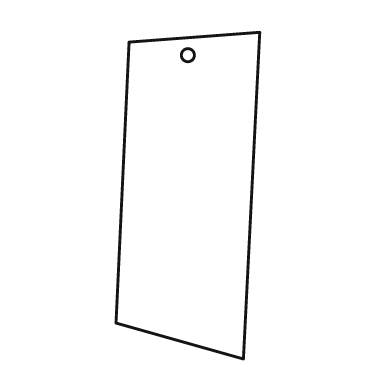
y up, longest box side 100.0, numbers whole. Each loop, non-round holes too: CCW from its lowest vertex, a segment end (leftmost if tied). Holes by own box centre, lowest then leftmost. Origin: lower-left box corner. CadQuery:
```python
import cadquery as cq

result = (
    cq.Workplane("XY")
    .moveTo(39.0, 0.0)
    .lineTo(44.0, 100.0)
    .lineTo(4.0, 97.0)
    .lineTo(0.0, 11.0)
    .close()
    .moveTo(22.0, 93.0)
    .circle(2.0)
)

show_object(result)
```